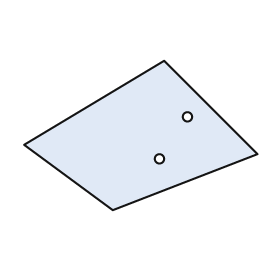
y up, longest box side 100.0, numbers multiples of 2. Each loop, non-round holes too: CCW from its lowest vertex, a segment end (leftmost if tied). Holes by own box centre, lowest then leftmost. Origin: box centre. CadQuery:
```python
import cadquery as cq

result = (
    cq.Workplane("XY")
    .moveTo(-12.0, -32.0)
    .lineTo(50.0, -8.0)
    .lineTo(10.0, 32.0)
    .lineTo(-50.0, -4.0)
    .close()
    .moveTo(8.0, -10.0)
    .circle(2.0)
    .moveTo(20.0, 8.0)
    .circle(2.0)
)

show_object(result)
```